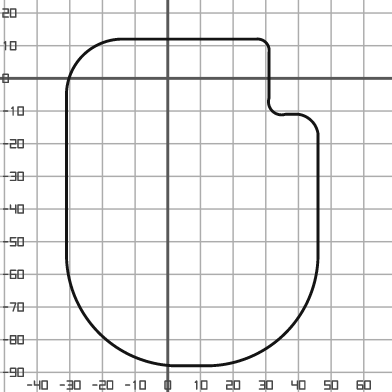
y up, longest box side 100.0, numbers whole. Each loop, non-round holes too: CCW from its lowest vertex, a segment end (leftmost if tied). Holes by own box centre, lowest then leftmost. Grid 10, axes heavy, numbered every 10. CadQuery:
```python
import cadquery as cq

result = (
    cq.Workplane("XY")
    .moveTo(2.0, -88.0)
    .lineTo(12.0, -88.0)
    .threePointArc((36.0, -78.0), (46.0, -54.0))
    .lineTo(46.0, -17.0)
    .threePointArc((44.0, -13.0), (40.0, -11.0))
    .lineTo(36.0, -11.0)
    .threePointArc((32.0, -10.0), (31.0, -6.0))
    .lineTo(31.0, 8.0)
    .threePointArc((30.0, 11.0), (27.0, 12.0))
    .lineTo(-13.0, 12.0)
    .threePointArc((-26.0, 7.0), (-31.0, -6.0))
    .lineTo(-31.0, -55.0)
    .threePointArc((-21.0, -78.0), (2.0, -88.0))
    .close()
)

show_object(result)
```